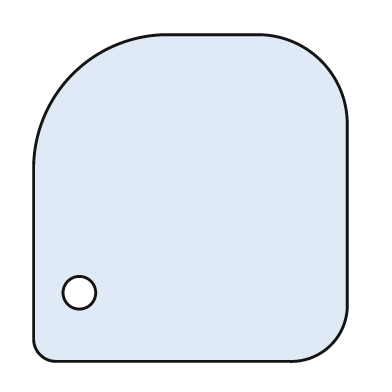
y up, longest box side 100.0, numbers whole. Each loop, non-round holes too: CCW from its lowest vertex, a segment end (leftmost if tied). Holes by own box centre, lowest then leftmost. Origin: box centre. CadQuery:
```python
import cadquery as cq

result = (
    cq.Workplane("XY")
    .moveTo(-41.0, -50.0)
    .lineTo(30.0, -50.0)
    .threePointArc((43.0, -45.0), (48.0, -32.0))
    .lineTo(48.0, 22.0)
    .threePointArc((40.0, 42.0), (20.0, 50.0))
    .lineTo(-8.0, 50.0)
    .threePointArc((-36.0, 38.0), (-48.0, 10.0))
    .lineTo(-48.0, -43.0)
    .threePointArc((-46.0, -48.0), (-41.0, -50.0))
    .close()
    .moveTo(-34.0, -29.0)
    .circle(5.0)
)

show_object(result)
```